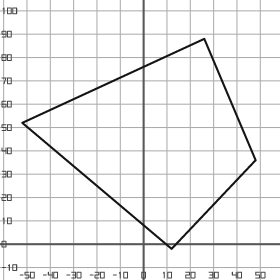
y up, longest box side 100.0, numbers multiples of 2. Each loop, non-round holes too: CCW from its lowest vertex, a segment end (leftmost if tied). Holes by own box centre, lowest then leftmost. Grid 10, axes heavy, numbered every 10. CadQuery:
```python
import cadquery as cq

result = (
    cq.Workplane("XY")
    .moveTo(12.0, -2.0)
    .lineTo(48.0, 36.0)
    .lineTo(26.0, 88.0)
    .lineTo(-52.0, 52.0)
    .close()
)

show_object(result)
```